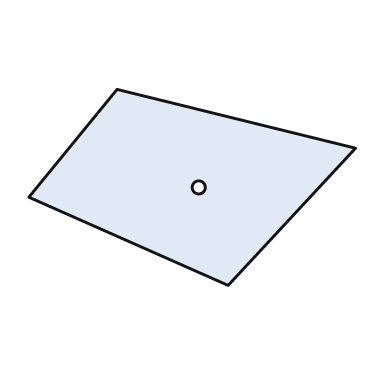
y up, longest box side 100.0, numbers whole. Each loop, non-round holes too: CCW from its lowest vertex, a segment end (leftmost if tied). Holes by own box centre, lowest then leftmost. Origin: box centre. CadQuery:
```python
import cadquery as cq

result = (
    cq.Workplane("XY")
    .moveTo(11.0, -30.0)
    .lineTo(50.0, 12.0)
    .lineTo(-23.0, 30.0)
    .lineTo(-50.0, -3.0)
    .close()
    .moveTo(2.0, 0.0)
    .circle(2.0)
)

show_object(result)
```